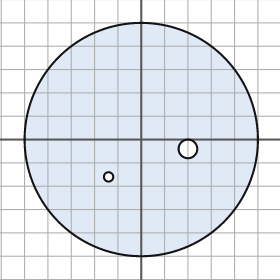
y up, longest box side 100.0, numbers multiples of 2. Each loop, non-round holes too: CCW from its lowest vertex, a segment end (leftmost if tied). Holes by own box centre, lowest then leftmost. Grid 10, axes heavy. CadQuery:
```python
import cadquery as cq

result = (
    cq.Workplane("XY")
    .moveTo(0.0, 0.0)
    .circle(50.0)
    .moveTo(-14.0, -16.0)
    .circle(2.0)
    .moveTo(20.0, -4.0)
    .circle(4.0)
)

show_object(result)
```